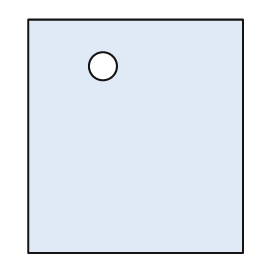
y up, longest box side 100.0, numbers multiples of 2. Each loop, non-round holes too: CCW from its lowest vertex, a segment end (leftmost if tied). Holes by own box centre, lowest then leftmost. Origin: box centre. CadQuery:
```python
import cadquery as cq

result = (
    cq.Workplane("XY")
    .moveTo(-46.0, -50.0)
    .lineTo(46.0, -50.0)
    .lineTo(46.0, 50.0)
    .lineTo(-46.0, 50.0)
    .close()
    .moveTo(-14.0, 30.0)
    .circle(6.0)
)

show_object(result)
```